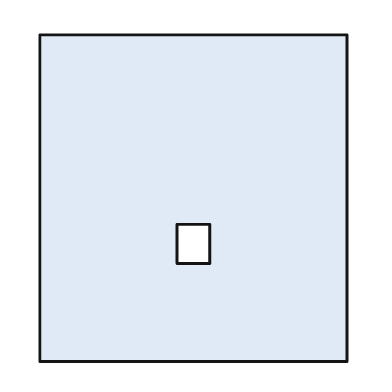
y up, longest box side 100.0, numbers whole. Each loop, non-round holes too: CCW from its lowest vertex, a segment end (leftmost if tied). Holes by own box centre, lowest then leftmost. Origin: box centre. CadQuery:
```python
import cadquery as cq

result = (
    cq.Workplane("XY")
    .moveTo(-47.0, -50.0)
    .lineTo(47.0, -50.0)
    .lineTo(47.0, 50.0)
    .lineTo(-47.0, 50.0)
    .close()
    .moveTo(-5.0, -20.0)
    .lineTo(5.0, -20.0)
    .lineTo(5.0, -8.0)
    .lineTo(-5.0, -8.0)
    .close()
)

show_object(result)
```